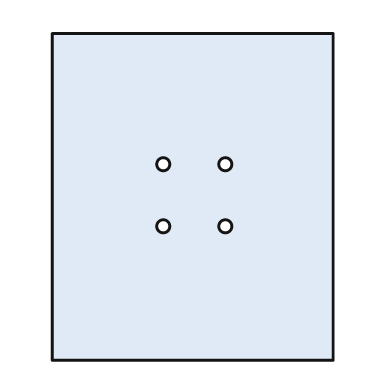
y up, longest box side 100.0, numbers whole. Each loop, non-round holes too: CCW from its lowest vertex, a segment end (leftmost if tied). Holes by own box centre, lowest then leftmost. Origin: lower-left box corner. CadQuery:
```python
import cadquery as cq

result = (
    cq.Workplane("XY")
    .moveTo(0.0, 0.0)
    .lineTo(86.0, 0.0)
    .lineTo(86.0, 100.0)
    .lineTo(0.0, 100.0)
    .close()
    .moveTo(34.0, 41.0)
    .circle(2.0)
    .moveTo(53.0, 41.0)
    .circle(2.0)
    .moveTo(34.0, 60.0)
    .circle(2.0)
    .moveTo(53.0, 60.0)
    .circle(2.0)
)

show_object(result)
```